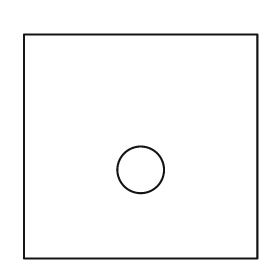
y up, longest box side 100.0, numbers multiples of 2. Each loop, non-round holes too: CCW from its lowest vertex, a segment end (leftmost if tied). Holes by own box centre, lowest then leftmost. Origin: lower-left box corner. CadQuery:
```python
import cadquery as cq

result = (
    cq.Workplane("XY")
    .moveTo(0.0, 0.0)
    .lineTo(100.0, 0.0)
    .lineTo(100.0, 96.0)
    .lineTo(0.0, 96.0)
    .close()
    .moveTo(50.0, 38.0)
    .circle(10.0)
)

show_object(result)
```